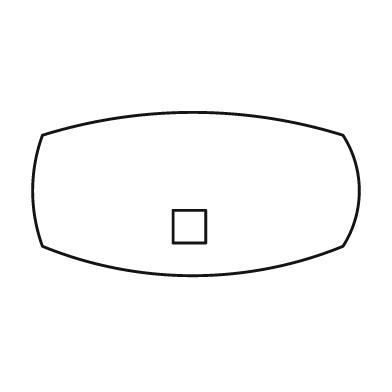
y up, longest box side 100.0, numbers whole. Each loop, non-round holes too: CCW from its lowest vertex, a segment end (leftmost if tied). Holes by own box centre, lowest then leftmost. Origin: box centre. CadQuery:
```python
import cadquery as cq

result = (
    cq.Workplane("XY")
    .moveTo(-47.0, -16.0)
    .threePointArc((-1.0, -25.0), (45.0, -16.0))
    .threePointArc((50.0, 1.0), (45.0, 18.0))
    .threePointArc((-1.0, 25.0), (-47.0, 18.0))
    .threePointArc((-50.0, 1.0), (-47.0, -16.0))
    .close()
    .moveTo(-7.0, -15.0)
    .lineTo(3.0, -15.0)
    .lineTo(3.0, -5.0)
    .lineTo(-7.0, -5.0)
    .close()
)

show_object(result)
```